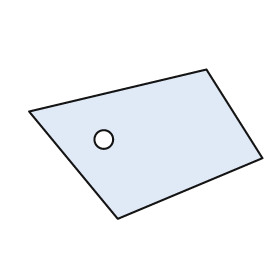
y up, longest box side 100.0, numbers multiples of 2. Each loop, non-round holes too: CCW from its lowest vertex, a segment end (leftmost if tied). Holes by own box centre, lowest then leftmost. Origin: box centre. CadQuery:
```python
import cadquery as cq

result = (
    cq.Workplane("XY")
    .moveTo(-12.0, -32.0)
    .lineTo(50.0, -6.0)
    .lineTo(26.0, 32.0)
    .lineTo(-50.0, 14.0)
    .close()
    .moveTo(-18.0, 2.0)
    .circle(4.0)
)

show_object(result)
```